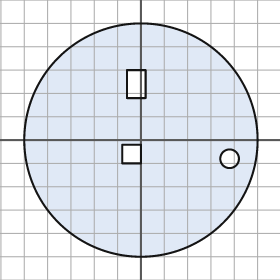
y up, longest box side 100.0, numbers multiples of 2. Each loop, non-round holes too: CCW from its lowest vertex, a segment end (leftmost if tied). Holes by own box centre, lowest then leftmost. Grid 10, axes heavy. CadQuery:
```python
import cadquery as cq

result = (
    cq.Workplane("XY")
    .moveTo(0.0, 0.0)
    .circle(50.0)
    .moveTo(38.0, -8.0)
    .circle(4.0)
    .moveTo(-8.0, -10.0)
    .lineTo(0.0, -10.0)
    .lineTo(0.0, -2.0)
    .lineTo(-8.0, -2.0)
    .close()
    .moveTo(-6.0, 18.0)
    .lineTo(2.0, 18.0)
    .lineTo(2.0, 30.0)
    .lineTo(-6.0, 30.0)
    .close()
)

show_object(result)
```